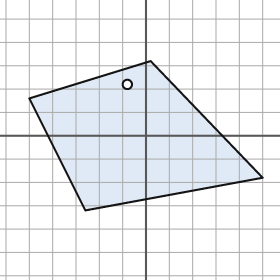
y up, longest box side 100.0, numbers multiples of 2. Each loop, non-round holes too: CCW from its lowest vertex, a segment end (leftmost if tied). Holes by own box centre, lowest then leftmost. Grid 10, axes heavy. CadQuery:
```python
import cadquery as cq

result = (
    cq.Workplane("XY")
    .moveTo(-26.0, -32.0)
    .lineTo(50.0, -18.0)
    .lineTo(2.0, 32.0)
    .lineTo(-50.0, 16.0)
    .close()
    .moveTo(-8.0, 22.0)
    .circle(2.0)
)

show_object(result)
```